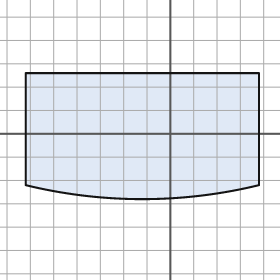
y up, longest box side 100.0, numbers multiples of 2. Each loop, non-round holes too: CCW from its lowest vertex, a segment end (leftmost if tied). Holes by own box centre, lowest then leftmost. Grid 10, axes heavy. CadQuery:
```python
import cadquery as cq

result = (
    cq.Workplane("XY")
    .moveTo(-62.0, -22.0)
    .threePointArc((-12.0, -28.0), (38.0, -22.0))
    .lineTo(38.0, 26.0)
    .lineTo(-62.0, 26.0)
    .close()
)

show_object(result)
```